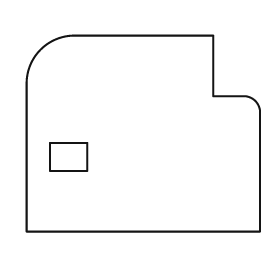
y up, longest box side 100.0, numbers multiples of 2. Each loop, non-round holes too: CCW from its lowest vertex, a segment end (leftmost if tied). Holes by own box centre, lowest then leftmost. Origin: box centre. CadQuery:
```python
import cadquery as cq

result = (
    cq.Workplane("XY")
    .moveTo(-50.0, -42.0)
    .lineTo(50.0, -42.0)
    .lineTo(50.0, 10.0)
    .threePointArc((48.0, 14.0), (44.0, 16.0))
    .lineTo(30.0, 16.0)
    .lineTo(30.0, 42.0)
    .lineTo(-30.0, 42.0)
    .threePointArc((-44.0, 36.0), (-50.0, 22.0))
    .close()
    .moveTo(-40.0, -16.0)
    .lineTo(-24.0, -16.0)
    .lineTo(-24.0, -4.0)
    .lineTo(-40.0, -4.0)
    .close()
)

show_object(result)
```